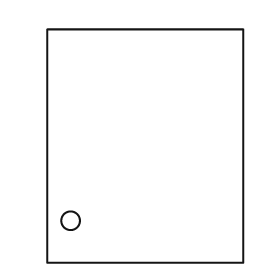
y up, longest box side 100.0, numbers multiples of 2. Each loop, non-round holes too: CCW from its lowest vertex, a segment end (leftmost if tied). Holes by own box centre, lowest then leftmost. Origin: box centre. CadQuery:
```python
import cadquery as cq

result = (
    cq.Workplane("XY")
    .moveTo(-42.0, -50.0)
    .lineTo(42.0, -50.0)
    .lineTo(42.0, 50.0)
    .lineTo(-42.0, 50.0)
    .close()
    .moveTo(-32.0, -32.0)
    .circle(4.0)
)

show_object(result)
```